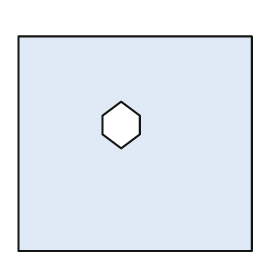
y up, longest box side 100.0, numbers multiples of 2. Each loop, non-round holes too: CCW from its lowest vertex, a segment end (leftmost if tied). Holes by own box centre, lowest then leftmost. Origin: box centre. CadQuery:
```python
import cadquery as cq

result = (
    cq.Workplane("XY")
    .moveTo(-50.0, -46.0)
    .lineTo(50.0, -46.0)
    .lineTo(50.0, 46.0)
    .lineTo(-50.0, 46.0)
    .close()
    .moveTo(-6.0, -2.0)
    .lineTo(2.0, 4.0)
    .lineTo(2.0, 12.0)
    .lineTo(-6.0, 18.0)
    .lineTo(-14.0, 12.0)
    .lineTo(-14.0, 4.0)
    .close()
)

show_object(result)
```